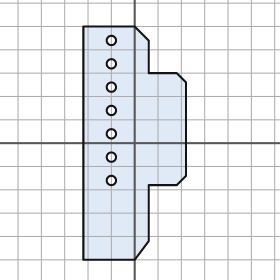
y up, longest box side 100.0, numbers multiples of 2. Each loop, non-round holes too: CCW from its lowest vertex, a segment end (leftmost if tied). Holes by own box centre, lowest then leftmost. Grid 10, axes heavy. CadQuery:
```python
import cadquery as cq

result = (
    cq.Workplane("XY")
    .moveTo(-22.0, -50.0)
    .lineTo(0.0, -50.0)
    .lineTo(6.0, -42.0)
    .lineTo(6.0, -18.0)
    .lineTo(18.0, -18.0)
    .lineTo(22.0, -14.0)
    .lineTo(22.0, 26.0)
    .lineTo(18.0, 30.0)
    .lineTo(6.0, 30.0)
    .lineTo(6.0, 44.0)
    .lineTo(0.0, 50.0)
    .lineTo(-22.0, 50.0)
    .close()
    .moveTo(-10.0, -16.0)
    .circle(2.0)
    .moveTo(-10.0, -6.0)
    .circle(2.0)
    .moveTo(-10.0, 4.0)
    .circle(2.0)
    .moveTo(-10.0, 14.0)
    .circle(2.0)
    .moveTo(-10.0, 24.0)
    .circle(2.0)
    .moveTo(-10.0, 34.0)
    .circle(2.0)
    .moveTo(-10.0, 44.0)
    .circle(2.0)
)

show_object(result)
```